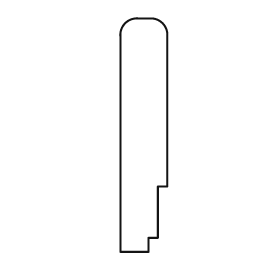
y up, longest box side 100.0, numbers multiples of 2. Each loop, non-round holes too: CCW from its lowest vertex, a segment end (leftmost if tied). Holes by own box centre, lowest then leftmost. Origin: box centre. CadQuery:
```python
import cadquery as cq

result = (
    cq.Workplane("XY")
    .moveTo(-10.0, -50.0)
    .lineTo(2.0, -50.0)
    .lineTo(2.0, -44.0)
    .lineTo(6.0, -44.0)
    .lineTo(6.0, -22.0)
    .lineTo(10.0, -22.0)
    .lineTo(10.0, 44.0)
    .threePointArc((8.0, 48.0), (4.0, 50.0))
    .lineTo(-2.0, 50.0)
    .threePointArc((-8.0, 48.0), (-10.0, 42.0))
    .close()
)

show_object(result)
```